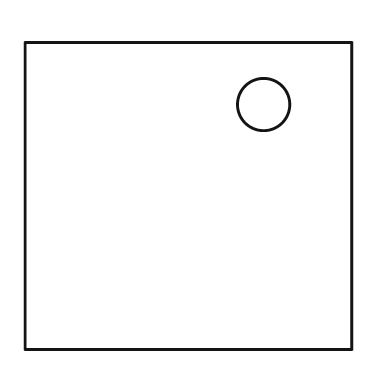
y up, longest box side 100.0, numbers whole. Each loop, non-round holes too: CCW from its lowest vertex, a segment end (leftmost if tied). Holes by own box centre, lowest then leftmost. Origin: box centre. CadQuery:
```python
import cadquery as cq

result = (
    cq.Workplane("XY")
    .moveTo(-50.0, -47.0)
    .lineTo(50.0, -47.0)
    .lineTo(50.0, 47.0)
    .lineTo(-50.0, 47.0)
    .close()
    .moveTo(23.0, 28.0)
    .circle(8.0)
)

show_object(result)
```